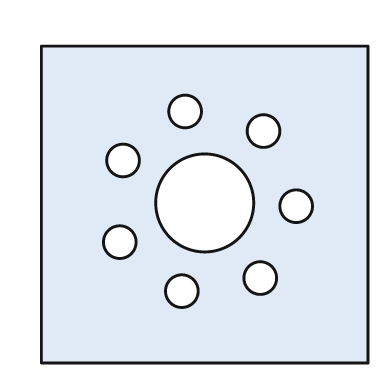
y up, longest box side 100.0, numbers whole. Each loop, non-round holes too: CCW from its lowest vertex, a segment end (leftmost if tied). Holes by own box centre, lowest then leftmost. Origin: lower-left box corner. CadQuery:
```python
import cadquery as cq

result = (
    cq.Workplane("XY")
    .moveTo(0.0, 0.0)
    .lineTo(100.0, 0.0)
    .lineTo(100.0, 97.0)
    .lineTo(0.0, 97.0)
    .close()
    .moveTo(43.0, 22.0)
    .circle(5.0)
    .moveTo(67.0, 26.0)
    .circle(5.0)
    .moveTo(24.0, 37.0)
    .circle(5.0)
    .moveTo(78.0, 48.0)
    .circle(5.0)
    .moveTo(50.0, 49.0)
    .circle(15.0)
    .moveTo(25.0, 62.0)
    .circle(5.0)
    .moveTo(68.0, 71.0)
    .circle(5.0)
    .moveTo(44.0, 77.0)
    .circle(5.0)
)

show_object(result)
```